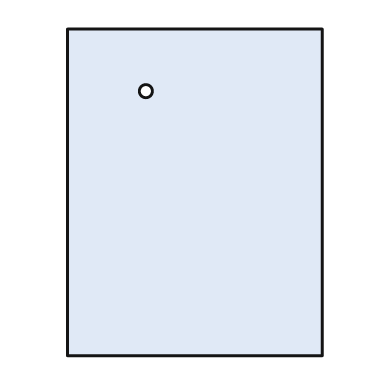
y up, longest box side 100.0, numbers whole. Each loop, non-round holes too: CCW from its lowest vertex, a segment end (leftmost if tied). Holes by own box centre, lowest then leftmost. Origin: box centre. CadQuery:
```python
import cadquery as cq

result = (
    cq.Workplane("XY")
    .moveTo(-39.0, -50.0)
    .lineTo(39.0, -50.0)
    .lineTo(39.0, 50.0)
    .lineTo(-39.0, 50.0)
    .close()
    .moveTo(-15.0, 31.0)
    .circle(2.0)
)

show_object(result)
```